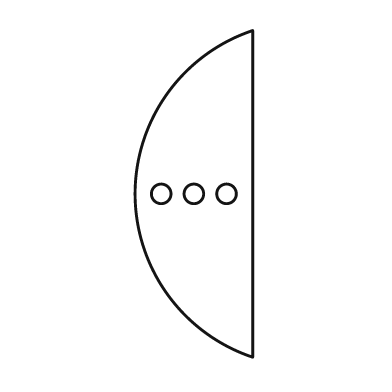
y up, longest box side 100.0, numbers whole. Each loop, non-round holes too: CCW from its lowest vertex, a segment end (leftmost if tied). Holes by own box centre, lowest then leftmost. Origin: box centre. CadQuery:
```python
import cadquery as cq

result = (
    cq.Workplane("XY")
    .moveTo(18.0, -50.0)
    .lineTo(18.0, 50.0)
    .threePointArc((-18.0, 0.0), (18.0, -50.0))
    .close()
    .moveTo(-10.0, 0.0)
    .circle(3.0)
    .moveTo(0.0, 0.0)
    .circle(3.0)
    .moveTo(10.0, 0.0)
    .circle(3.0)
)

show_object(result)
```